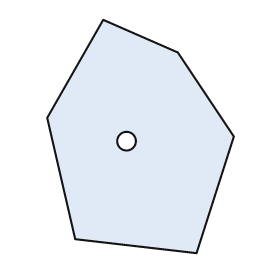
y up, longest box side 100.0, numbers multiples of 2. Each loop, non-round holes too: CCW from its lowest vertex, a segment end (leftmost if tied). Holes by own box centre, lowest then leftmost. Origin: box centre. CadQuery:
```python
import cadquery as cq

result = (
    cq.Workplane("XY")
    .moveTo(24.0, -50.0)
    .lineTo(40.0, 0.0)
    .lineTo(16.0, 36.0)
    .lineTo(-16.0, 50.0)
    .lineTo(-40.0, 8.0)
    .lineTo(-28.0, -44.0)
    .close()
    .moveTo(-6.0, -2.0)
    .circle(4.0)
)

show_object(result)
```